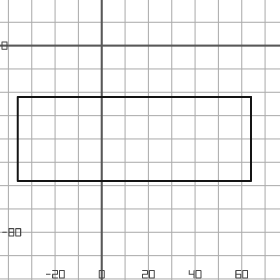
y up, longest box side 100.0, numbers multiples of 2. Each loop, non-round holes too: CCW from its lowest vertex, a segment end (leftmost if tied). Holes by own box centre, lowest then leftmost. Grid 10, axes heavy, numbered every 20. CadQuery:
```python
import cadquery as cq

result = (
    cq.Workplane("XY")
    .moveTo(-36.0, -58.0)
    .lineTo(64.0, -58.0)
    .lineTo(64.0, -22.0)
    .lineTo(-36.0, -22.0)
    .close()
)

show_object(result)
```